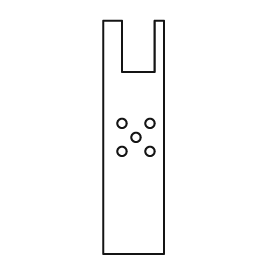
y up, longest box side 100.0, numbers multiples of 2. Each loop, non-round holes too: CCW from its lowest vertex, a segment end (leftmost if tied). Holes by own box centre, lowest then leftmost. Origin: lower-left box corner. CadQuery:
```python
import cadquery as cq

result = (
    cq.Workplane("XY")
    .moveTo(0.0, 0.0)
    .lineTo(26.0, 0.0)
    .lineTo(26.0, 100.0)
    .lineTo(22.0, 100.0)
    .lineTo(22.0, 78.0)
    .lineTo(8.0, 78.0)
    .lineTo(8.0, 100.0)
    .lineTo(0.0, 100.0)
    .close()
    .moveTo(8.0, 44.0)
    .circle(2.0)
    .moveTo(20.0, 44.0)
    .circle(2.0)
    .moveTo(14.0, 50.0)
    .circle(2.0)
    .moveTo(8.0, 56.0)
    .circle(2.0)
    .moveTo(20.0, 56.0)
    .circle(2.0)
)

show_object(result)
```